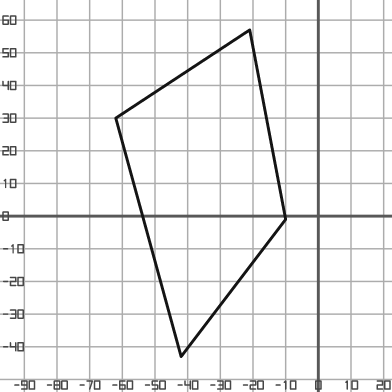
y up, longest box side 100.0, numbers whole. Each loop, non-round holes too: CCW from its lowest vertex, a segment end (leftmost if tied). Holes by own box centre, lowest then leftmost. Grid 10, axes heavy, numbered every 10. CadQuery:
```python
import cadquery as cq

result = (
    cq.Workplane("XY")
    .moveTo(-42.0, -43.0)
    .lineTo(-10.0, -1.0)
    .lineTo(-21.0, 57.0)
    .lineTo(-62.0, 30.0)
    .close()
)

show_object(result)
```